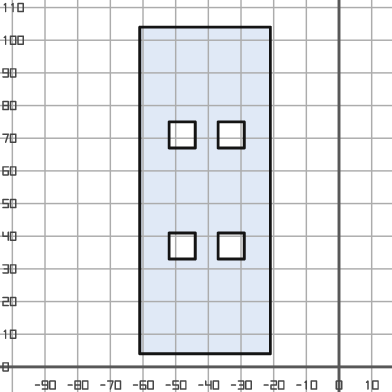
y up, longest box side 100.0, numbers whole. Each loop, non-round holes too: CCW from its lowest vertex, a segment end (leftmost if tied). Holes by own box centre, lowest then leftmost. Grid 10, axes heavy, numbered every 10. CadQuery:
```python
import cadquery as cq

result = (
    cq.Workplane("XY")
    .moveTo(-61.0, 4.0)
    .lineTo(-21.0, 4.0)
    .lineTo(-21.0, 104.0)
    .lineTo(-61.0, 104.0)
    .close()
    .moveTo(-52.0, 33.0)
    .lineTo(-44.0, 33.0)
    .lineTo(-44.0, 41.0)
    .lineTo(-52.0, 41.0)
    .close()
    .moveTo(-37.0, 33.0)
    .lineTo(-29.0, 33.0)
    .lineTo(-29.0, 41.0)
    .lineTo(-37.0, 41.0)
    .close()
    .moveTo(-52.0, 67.0)
    .lineTo(-44.0, 67.0)
    .lineTo(-44.0, 75.0)
    .lineTo(-52.0, 75.0)
    .close()
    .moveTo(-37.0, 67.0)
    .lineTo(-29.0, 67.0)
    .lineTo(-29.0, 75.0)
    .lineTo(-37.0, 75.0)
    .close()
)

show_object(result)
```